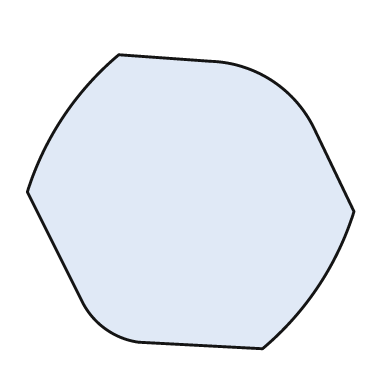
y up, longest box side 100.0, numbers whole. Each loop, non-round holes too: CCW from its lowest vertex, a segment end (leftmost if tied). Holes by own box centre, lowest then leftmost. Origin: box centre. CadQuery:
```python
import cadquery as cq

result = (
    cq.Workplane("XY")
    .moveTo(22.0, -45.0)
    .threePointArc((39.0, -26.0), (50.0, -3.0))
    .lineTo(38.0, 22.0)
    .threePointArc((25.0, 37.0), (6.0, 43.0))
    .lineTo(-22.0, 45.0)
    .threePointArc((-39.0, 26.0), (-50.0, 3.0))
    .lineTo(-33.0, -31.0)
    .threePointArc((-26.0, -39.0), (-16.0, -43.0))
    .close()
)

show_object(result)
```